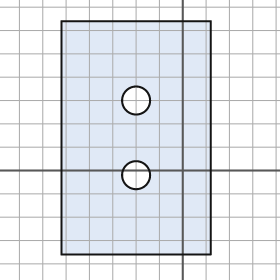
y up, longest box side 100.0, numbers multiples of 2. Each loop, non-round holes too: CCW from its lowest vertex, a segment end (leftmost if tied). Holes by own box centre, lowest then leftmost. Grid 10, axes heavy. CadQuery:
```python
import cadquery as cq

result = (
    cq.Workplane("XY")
    .moveTo(-52.0, -36.0)
    .lineTo(12.0, -36.0)
    .lineTo(12.0, 64.0)
    .lineTo(-52.0, 64.0)
    .close()
    .moveTo(-20.0, -2.0)
    .circle(6.0)
    .moveTo(-20.0, 30.0)
    .circle(6.0)
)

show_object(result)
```